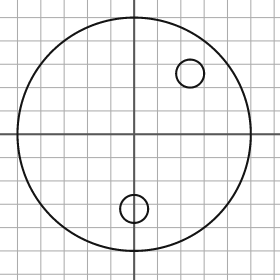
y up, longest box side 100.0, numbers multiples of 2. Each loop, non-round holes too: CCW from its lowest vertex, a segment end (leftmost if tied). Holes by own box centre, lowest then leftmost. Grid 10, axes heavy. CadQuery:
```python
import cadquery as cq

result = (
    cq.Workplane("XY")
    .moveTo(0.0, 0.0)
    .circle(50.0)
    .moveTo(0.0, -32.0)
    .circle(6.0)
    .moveTo(24.0, 26.0)
    .circle(6.0)
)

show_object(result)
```